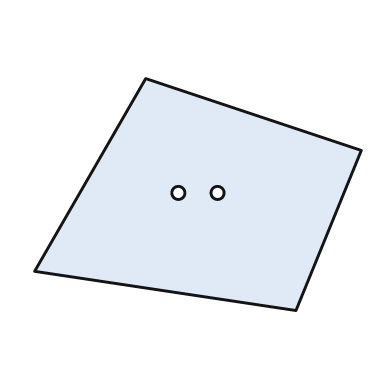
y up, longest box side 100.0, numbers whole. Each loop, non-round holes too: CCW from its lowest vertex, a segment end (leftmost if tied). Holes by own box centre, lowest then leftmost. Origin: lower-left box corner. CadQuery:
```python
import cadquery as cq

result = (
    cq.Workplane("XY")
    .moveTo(80.0, 0.0)
    .lineTo(100.0, 49.0)
    .lineTo(34.0, 71.0)
    .lineTo(0.0, 12.0)
    .close()
    .moveTo(44.0, 36.0)
    .circle(2.0)
    .moveTo(56.0, 36.0)
    .circle(2.0)
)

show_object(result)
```